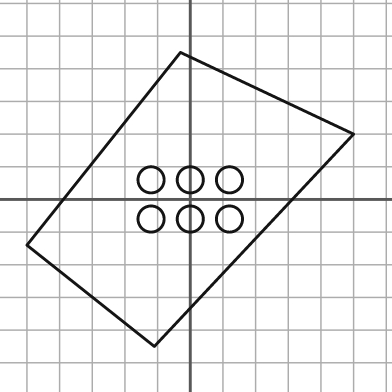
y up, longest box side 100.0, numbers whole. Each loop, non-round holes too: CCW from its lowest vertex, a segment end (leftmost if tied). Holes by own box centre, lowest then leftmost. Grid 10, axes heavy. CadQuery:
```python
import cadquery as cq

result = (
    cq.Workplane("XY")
    .moveTo(-11.0, -45.0)
    .lineTo(50.0, 20.0)
    .lineTo(-3.0, 45.0)
    .lineTo(-50.0, -14.0)
    .close()
    .moveTo(-12.0, -6.0)
    .circle(4.0)
    .moveTo(0.0, -6.0)
    .circle(4.0)
    .moveTo(12.0, -6.0)
    .circle(4.0)
    .moveTo(-12.0, 6.0)
    .circle(4.0)
    .moveTo(0.0, 6.0)
    .circle(4.0)
    .moveTo(12.0, 6.0)
    .circle(4.0)
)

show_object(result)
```